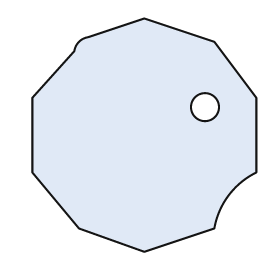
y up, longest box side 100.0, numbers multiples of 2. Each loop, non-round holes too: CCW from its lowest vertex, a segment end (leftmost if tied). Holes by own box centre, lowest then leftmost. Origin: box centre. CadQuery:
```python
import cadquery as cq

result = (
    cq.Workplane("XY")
    .moveTo(0.0, -50.0)
    .lineTo(30.0, -40.0)
    .threePointArc((36.0, -26.0), (48.0, -16.0))
    .lineTo(48.0, 16.0)
    .lineTo(30.0, 40.0)
    .lineTo(0.0, 50.0)
    .lineTo(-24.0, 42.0)
    .threePointArc((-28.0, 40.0), (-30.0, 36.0))
    .lineTo(-48.0, 16.0)
    .lineTo(-48.0, -16.0)
    .lineTo(-28.0, -40.0)
    .close()
    .moveTo(26.0, 12.0)
    .circle(6.0)
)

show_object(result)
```